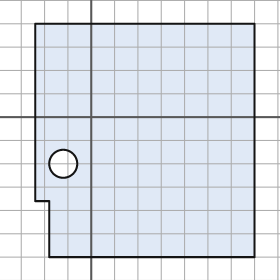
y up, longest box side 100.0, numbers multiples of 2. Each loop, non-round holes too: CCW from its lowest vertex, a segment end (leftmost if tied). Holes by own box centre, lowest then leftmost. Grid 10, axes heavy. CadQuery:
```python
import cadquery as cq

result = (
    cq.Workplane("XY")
    .moveTo(-18.0, -60.0)
    .lineTo(70.0, -60.0)
    .lineTo(70.0, 40.0)
    .lineTo(-24.0, 40.0)
    .lineTo(-24.0, -36.0)
    .lineTo(-18.0, -36.0)
    .close()
    .moveTo(-12.0, -20.0)
    .circle(6.0)
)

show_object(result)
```